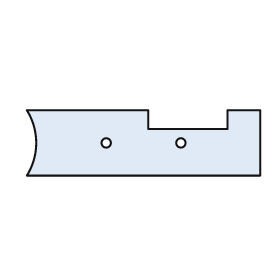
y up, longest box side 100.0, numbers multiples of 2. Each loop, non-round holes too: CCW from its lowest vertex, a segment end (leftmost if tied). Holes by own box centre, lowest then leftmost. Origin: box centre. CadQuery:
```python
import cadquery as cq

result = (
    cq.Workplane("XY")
    .moveTo(-50.0, -14.0)
    .lineTo(50.0, -14.0)
    .lineTo(50.0, 14.0)
    .lineTo(36.0, 14.0)
    .lineTo(36.0, 6.0)
    .lineTo(2.0, 6.0)
    .lineTo(2.0, 14.0)
    .lineTo(-50.0, 14.0)
    .threePointArc((-46.0, 0.0), (-50.0, -14.0))
    .close()
    .moveTo(-16.0, 0.0)
    .circle(2.0)
    .moveTo(16.0, 0.0)
    .circle(2.0)
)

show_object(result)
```